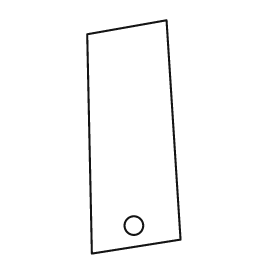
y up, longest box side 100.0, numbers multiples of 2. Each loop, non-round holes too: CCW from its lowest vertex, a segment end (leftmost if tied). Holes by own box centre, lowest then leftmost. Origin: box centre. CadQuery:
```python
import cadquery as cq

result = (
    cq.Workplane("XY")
    .moveTo(-18.0, -50.0)
    .lineTo(20.0, -44.0)
    .lineTo(14.0, 50.0)
    .lineTo(-20.0, 44.0)
    .close()
    .moveTo(0.0, -38.0)
    .circle(4.0)
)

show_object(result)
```